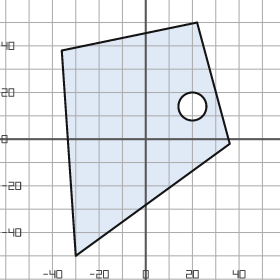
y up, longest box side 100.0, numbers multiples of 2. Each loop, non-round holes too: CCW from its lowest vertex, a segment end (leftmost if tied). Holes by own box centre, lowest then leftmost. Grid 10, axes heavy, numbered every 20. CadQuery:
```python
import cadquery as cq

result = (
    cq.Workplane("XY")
    .moveTo(-30.0, -50.0)
    .lineTo(36.0, -2.0)
    .lineTo(22.0, 50.0)
    .lineTo(-36.0, 38.0)
    .close()
    .moveTo(20.0, 14.0)
    .circle(6.0)
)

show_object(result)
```